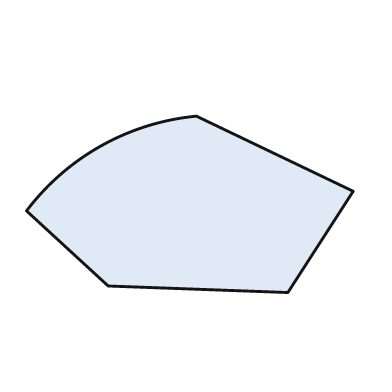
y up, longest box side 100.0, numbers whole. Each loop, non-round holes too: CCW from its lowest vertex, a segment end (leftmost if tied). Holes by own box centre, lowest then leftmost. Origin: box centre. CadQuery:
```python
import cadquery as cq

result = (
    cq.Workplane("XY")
    .moveTo(30.0, -27.0)
    .lineTo(50.0, 4.0)
    .lineTo(2.0, 27.0)
    .threePointArc((-27.0, 18.0), (-50.0, -2.0))
    .lineTo(-25.0, -25.0)
    .close()
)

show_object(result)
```